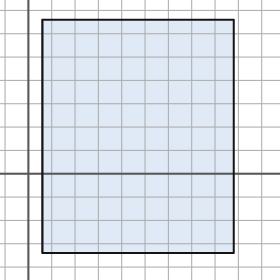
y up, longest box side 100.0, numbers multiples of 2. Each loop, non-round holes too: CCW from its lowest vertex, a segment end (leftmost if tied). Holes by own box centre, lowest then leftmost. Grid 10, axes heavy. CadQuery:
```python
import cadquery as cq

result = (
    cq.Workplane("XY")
    .moveTo(6.0, -34.0)
    .lineTo(88.0, -34.0)
    .lineTo(88.0, 66.0)
    .lineTo(6.0, 66.0)
    .close()
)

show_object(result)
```